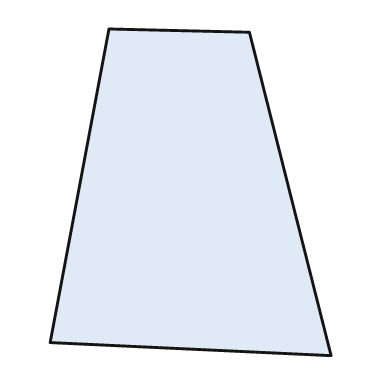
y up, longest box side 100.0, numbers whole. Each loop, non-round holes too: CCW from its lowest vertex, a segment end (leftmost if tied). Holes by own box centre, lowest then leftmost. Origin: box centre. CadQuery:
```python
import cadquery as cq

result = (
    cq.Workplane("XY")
    .moveTo(43.0, -50.0)
    .lineTo(18.0, 49.0)
    .lineTo(-25.0, 50.0)
    .lineTo(-43.0, -46.0)
    .close()
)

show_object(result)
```